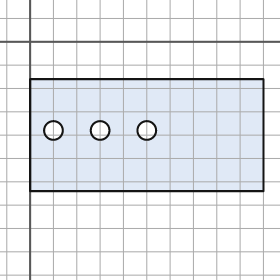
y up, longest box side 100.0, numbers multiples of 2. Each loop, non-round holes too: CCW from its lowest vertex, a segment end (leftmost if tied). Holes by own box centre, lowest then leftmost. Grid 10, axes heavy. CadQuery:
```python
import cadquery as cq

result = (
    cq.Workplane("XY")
    .moveTo(0.0, -64.0)
    .lineTo(100.0, -64.0)
    .lineTo(100.0, -16.0)
    .lineTo(0.0, -16.0)
    .close()
    .moveTo(10.0, -38.0)
    .circle(4.0)
    .moveTo(30.0, -38.0)
    .circle(4.0)
    .moveTo(50.0, -38.0)
    .circle(4.0)
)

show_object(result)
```